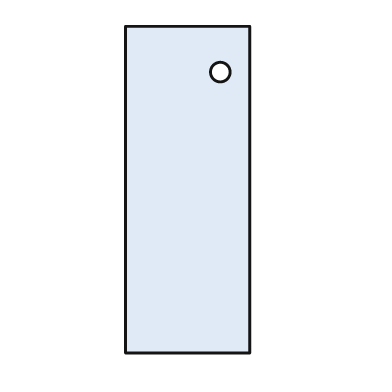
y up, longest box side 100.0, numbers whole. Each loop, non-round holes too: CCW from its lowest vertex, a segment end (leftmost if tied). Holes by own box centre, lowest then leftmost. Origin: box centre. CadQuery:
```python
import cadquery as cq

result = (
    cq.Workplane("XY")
    .moveTo(-19.0, -50.0)
    .lineTo(19.0, -50.0)
    .lineTo(19.0, 50.0)
    .lineTo(-19.0, 50.0)
    .close()
    .moveTo(10.0, 36.0)
    .circle(3.0)
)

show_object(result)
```